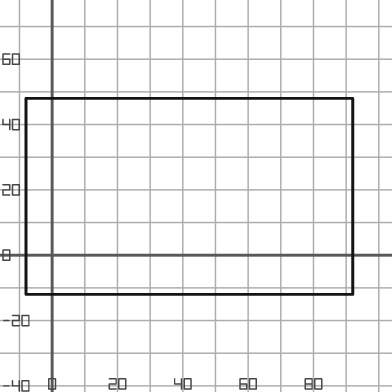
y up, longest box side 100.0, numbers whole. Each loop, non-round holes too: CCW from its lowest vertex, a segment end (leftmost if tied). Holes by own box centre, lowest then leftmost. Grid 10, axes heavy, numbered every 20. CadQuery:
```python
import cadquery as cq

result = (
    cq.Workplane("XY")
    .moveTo(-8.0, -12.0)
    .lineTo(92.0, -12.0)
    .lineTo(92.0, 48.0)
    .lineTo(-8.0, 48.0)
    .close()
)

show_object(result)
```